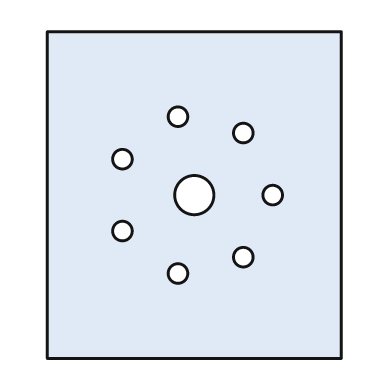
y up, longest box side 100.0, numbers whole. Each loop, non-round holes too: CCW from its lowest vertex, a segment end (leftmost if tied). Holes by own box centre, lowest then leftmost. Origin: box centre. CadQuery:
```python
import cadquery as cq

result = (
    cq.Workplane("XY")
    .moveTo(-45.0, -50.0)
    .lineTo(45.0, -50.0)
    .lineTo(45.0, 50.0)
    .lineTo(-45.0, 50.0)
    .close()
    .moveTo(-5.0, -24.0)
    .circle(3.0)
    .moveTo(15.0, -19.0)
    .circle(3.0)
    .moveTo(-22.0, -11.0)
    .circle(3.0)
    .moveTo(0.0, 0.0)
    .circle(6.0)
    .moveTo(24.0, 0.0)
    .circle(3.0)
    .moveTo(-22.0, 11.0)
    .circle(3.0)
    .moveTo(15.0, 19.0)
    .circle(3.0)
    .moveTo(-5.0, 24.0)
    .circle(3.0)
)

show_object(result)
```